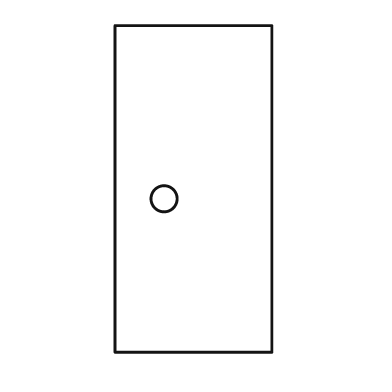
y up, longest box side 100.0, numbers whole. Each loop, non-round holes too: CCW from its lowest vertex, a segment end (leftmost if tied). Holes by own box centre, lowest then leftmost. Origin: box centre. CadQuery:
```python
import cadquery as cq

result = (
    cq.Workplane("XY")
    .moveTo(-24.0, -50.0)
    .lineTo(24.0, -50.0)
    .lineTo(24.0, 50.0)
    .lineTo(-24.0, 50.0)
    .close()
    .moveTo(-9.0, -3.0)
    .circle(4.0)
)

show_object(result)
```